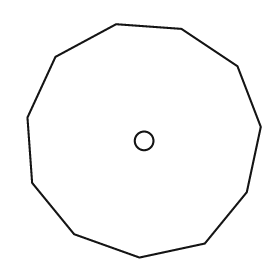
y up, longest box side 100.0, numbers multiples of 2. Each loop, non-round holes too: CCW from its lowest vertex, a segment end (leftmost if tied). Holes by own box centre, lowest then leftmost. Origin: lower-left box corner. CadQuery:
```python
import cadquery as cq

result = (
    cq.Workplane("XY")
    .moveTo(48.0, 0.0)
    .lineTo(76.0, 6.0)
    .lineTo(94.0, 28.0)
    .lineTo(100.0, 56.0)
    .lineTo(90.0, 82.0)
    .lineTo(66.0, 98.0)
    .lineTo(38.0, 100.0)
    .lineTo(12.0, 86.0)
    .lineTo(0.0, 60.0)
    .lineTo(2.0, 32.0)
    .lineTo(20.0, 10.0)
    .close()
    .moveTo(50.0, 50.0)
    .circle(4.0)
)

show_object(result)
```